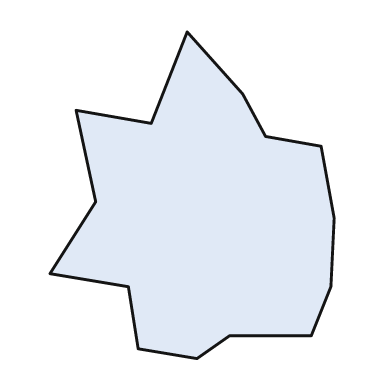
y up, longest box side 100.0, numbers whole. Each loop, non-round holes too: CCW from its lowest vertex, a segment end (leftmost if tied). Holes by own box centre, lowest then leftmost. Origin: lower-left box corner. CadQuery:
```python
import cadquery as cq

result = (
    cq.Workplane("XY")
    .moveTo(45.0, 0.0)
    .lineTo(55.0, 7.0)
    .lineTo(80.0, 7.0)
    .lineTo(86.0, 22.0)
    .lineTo(87.0, 43.0)
    .lineTo(83.0, 65.0)
    .lineTo(66.0, 68.0)
    .lineTo(59.0, 81.0)
    .lineTo(42.0, 100.0)
    .lineTo(31.0, 72.0)
    .lineTo(8.0, 76.0)
    .lineTo(14.0, 48.0)
    .lineTo(0.0, 26.0)
    .lineTo(24.0, 22.0)
    .lineTo(27.0, 3.0)
    .close()
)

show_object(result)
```